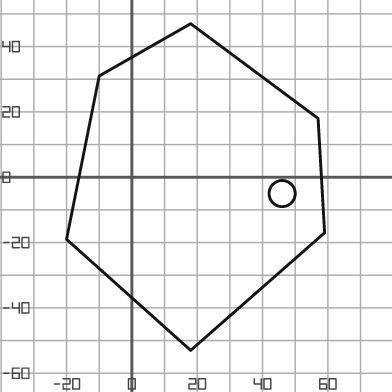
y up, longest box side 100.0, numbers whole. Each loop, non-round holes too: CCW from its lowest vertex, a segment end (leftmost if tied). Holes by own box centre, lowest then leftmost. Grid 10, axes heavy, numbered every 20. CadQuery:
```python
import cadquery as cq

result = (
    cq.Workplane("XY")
    .moveTo(18.0, -53.0)
    .lineTo(59.0, -17.0)
    .lineTo(57.0, 18.0)
    .lineTo(18.0, 47.0)
    .lineTo(-10.0, 31.0)
    .lineTo(-20.0, -19.0)
    .close()
    .moveTo(46.0, -5.0)
    .circle(4.0)
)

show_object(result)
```